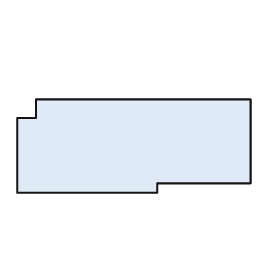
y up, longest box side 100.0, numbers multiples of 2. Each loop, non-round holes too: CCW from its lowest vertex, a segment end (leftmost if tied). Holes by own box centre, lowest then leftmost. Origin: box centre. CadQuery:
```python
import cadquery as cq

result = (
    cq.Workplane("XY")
    .moveTo(-50.0, -20.0)
    .lineTo(10.0, -20.0)
    .lineTo(10.0, -16.0)
    .lineTo(50.0, -16.0)
    .lineTo(50.0, 20.0)
    .lineTo(-42.0, 20.0)
    .lineTo(-42.0, 12.0)
    .lineTo(-50.0, 12.0)
    .close()
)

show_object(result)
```